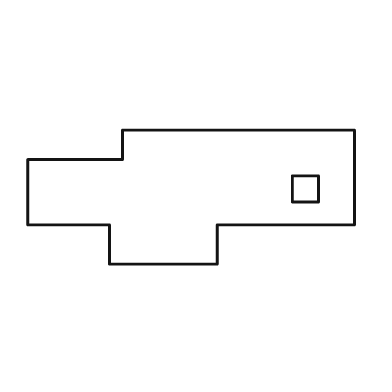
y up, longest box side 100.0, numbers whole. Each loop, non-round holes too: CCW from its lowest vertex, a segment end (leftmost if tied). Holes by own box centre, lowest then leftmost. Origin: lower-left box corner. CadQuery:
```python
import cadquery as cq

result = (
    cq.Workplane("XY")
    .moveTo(25.0, 0.0)
    .lineTo(58.0, 0.0)
    .lineTo(58.0, 12.0)
    .lineTo(100.0, 12.0)
    .lineTo(100.0, 41.0)
    .lineTo(29.0, 41.0)
    .lineTo(29.0, 32.0)
    .lineTo(0.0, 32.0)
    .lineTo(0.0, 12.0)
    .lineTo(25.0, 12.0)
    .close()
    .moveTo(81.0, 19.0)
    .lineTo(89.0, 19.0)
    .lineTo(89.0, 27.0)
    .lineTo(81.0, 27.0)
    .close()
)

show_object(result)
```